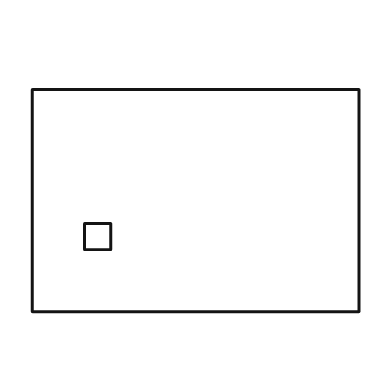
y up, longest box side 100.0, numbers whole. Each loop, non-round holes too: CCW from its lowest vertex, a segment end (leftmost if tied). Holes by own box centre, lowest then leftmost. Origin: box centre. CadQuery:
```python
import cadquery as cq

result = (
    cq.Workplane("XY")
    .moveTo(-50.0, -34.0)
    .lineTo(50.0, -34.0)
    .lineTo(50.0, 34.0)
    .lineTo(-50.0, 34.0)
    .close()
    .moveTo(-34.0, -15.0)
    .lineTo(-26.0, -15.0)
    .lineTo(-26.0, -7.0)
    .lineTo(-34.0, -7.0)
    .close()
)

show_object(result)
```